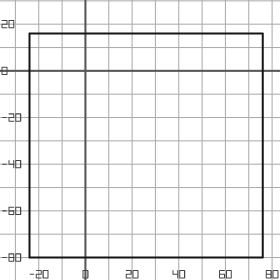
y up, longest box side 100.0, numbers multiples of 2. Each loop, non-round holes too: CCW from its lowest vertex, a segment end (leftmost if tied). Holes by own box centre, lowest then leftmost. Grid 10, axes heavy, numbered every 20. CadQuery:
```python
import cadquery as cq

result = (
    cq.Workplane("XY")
    .moveTo(-24.0, -80.0)
    .lineTo(76.0, -80.0)
    .lineTo(76.0, 16.0)
    .lineTo(-24.0, 16.0)
    .close()
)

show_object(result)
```